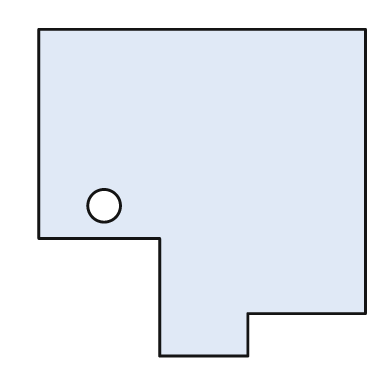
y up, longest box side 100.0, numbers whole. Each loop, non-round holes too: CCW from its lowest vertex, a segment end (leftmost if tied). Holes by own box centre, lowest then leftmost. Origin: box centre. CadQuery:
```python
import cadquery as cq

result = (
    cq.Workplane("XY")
    .moveTo(-13.0, -50.0)
    .lineTo(14.0, -50.0)
    .lineTo(14.0, -37.0)
    .lineTo(50.0, -37.0)
    .lineTo(50.0, 50.0)
    .lineTo(-50.0, 50.0)
    .lineTo(-50.0, -14.0)
    .lineTo(-13.0, -14.0)
    .close()
    .moveTo(-30.0, -4.0)
    .circle(5.0)
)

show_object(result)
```